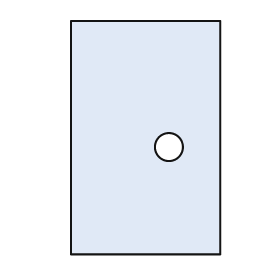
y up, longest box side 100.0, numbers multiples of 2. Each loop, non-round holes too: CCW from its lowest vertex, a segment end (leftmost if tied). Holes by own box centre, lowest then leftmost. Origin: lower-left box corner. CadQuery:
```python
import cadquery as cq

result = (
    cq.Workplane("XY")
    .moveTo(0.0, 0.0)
    .lineTo(64.0, 0.0)
    .lineTo(64.0, 100.0)
    .lineTo(0.0, 100.0)
    .close()
    .moveTo(42.0, 46.0)
    .circle(6.0)
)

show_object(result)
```